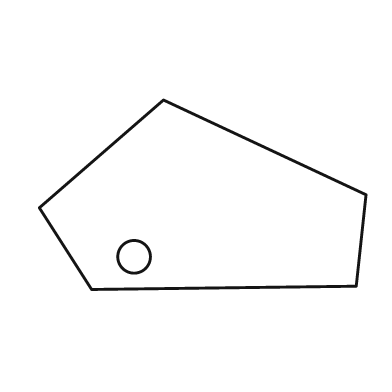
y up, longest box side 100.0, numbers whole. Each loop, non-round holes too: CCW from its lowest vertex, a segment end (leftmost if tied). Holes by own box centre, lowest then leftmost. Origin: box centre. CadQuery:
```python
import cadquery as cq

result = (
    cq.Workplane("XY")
    .moveTo(-34.0, -29.0)
    .lineTo(47.0, -28.0)
    .lineTo(50.0, 0.0)
    .lineTo(-12.0, 29.0)
    .lineTo(-50.0, -4.0)
    .close()
    .moveTo(-21.0, -19.0)
    .circle(5.0)
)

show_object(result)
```